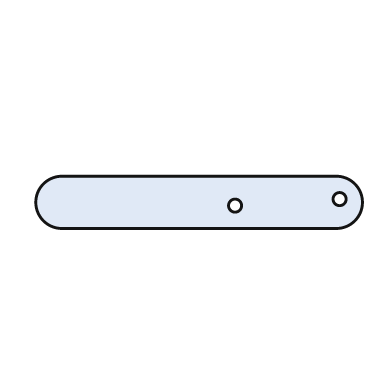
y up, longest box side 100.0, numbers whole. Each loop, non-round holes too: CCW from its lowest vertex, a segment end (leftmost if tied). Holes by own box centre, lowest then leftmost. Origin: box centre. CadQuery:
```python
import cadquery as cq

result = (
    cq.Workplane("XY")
    .moveTo(-42.0, -8.0)
    .lineTo(42.0, -8.0)
    .threePointArc((50.0, 0.0), (42.0, 8.0))
    .lineTo(-42.0, 8.0)
    .threePointArc((-50.0, 0.0), (-42.0, -8.0))
    .close()
    .moveTo(11.0, -1.0)
    .circle(2.0)
    .moveTo(43.0, 1.0)
    .circle(2.0)
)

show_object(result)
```